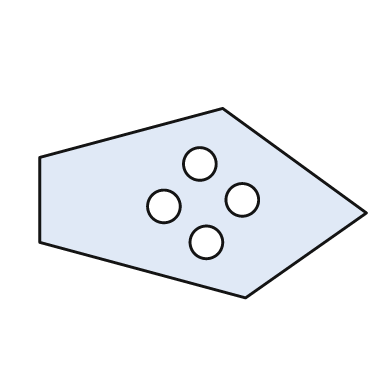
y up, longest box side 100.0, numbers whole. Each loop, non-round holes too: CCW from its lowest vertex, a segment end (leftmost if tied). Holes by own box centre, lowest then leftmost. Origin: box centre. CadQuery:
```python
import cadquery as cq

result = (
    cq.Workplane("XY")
    .moveTo(13.0, -29.0)
    .lineTo(50.0, -3.0)
    .lineTo(6.0, 29.0)
    .lineTo(-50.0, 14.0)
    .lineTo(-50.0, -12.0)
    .close()
    .moveTo(1.0, -12.0)
    .circle(5.0)
    .moveTo(-12.0, -1.0)
    .circle(5.0)
    .moveTo(12.0, 1.0)
    .circle(5.0)
    .moveTo(-1.0, 12.0)
    .circle(5.0)
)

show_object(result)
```